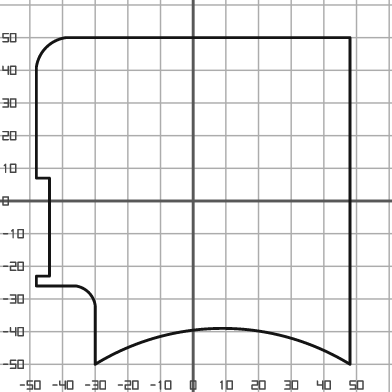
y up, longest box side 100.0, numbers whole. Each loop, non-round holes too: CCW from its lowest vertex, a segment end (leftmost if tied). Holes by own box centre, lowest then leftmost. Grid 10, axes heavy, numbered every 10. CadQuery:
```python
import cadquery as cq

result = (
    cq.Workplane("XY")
    .moveTo(-30.0, -50.0)
    .threePointArc((9.0, -39.0), (48.0, -50.0))
    .lineTo(48.0, 50.0)
    .lineTo(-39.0, 50.0)
    .threePointArc((-45.0, 47.0), (-48.0, 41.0))
    .lineTo(-48.0, 7.0)
    .lineTo(-44.0, 7.0)
    .lineTo(-44.0, -23.0)
    .lineTo(-48.0, -23.0)
    .lineTo(-48.0, -26.0)
    .lineTo(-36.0, -26.0)
    .threePointArc((-32.0, -28.0), (-30.0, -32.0))
    .close()
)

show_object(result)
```